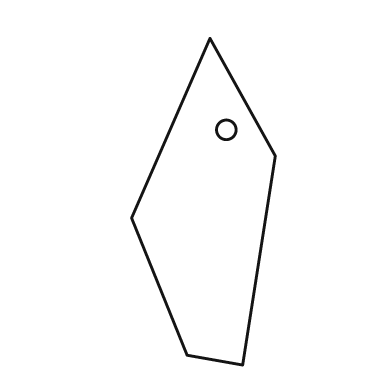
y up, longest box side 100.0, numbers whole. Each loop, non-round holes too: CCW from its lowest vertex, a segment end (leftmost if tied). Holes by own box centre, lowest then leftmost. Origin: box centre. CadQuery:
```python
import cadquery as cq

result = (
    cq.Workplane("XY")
    .moveTo(12.0, -50.0)
    .lineTo(22.0, 14.0)
    .lineTo(2.0, 50.0)
    .lineTo(-22.0, -5.0)
    .lineTo(-5.0, -47.0)
    .close()
    .moveTo(7.0, 22.0)
    .circle(3.0)
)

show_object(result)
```